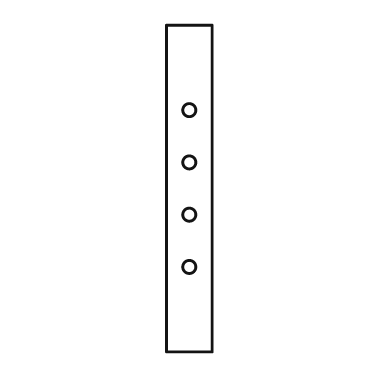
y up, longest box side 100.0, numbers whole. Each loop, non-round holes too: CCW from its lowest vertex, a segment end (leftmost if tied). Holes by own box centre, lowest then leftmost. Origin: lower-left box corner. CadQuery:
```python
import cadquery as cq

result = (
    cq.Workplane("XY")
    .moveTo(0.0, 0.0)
    .lineTo(14.0, 0.0)
    .lineTo(14.0, 100.0)
    .lineTo(0.0, 100.0)
    .close()
    .moveTo(7.0, 26.0)
    .circle(2.0)
    .moveTo(7.0, 42.0)
    .circle(2.0)
    .moveTo(7.0, 58.0)
    .circle(2.0)
    .moveTo(7.0, 74.0)
    .circle(2.0)
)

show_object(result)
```